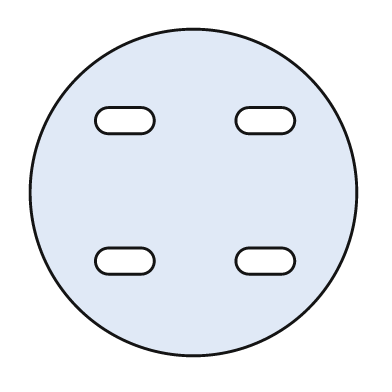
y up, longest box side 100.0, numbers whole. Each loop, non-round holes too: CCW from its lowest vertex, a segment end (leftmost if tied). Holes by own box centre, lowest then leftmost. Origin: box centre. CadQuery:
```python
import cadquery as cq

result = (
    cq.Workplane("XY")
    .moveTo(0.0, 0.0)
    .circle(50.0)
    .moveTo(-26.0, -25.0)
    .lineTo(-16.0, -25.0)
    .threePointArc((-12.0, -21.0), (-16.0, -17.0))
    .lineTo(-26.0, -17.0)
    .threePointArc((-30.0, -21.0), (-26.0, -25.0))
    .close()
    .moveTo(17.0, -25.0)
    .lineTo(27.0, -25.0)
    .threePointArc((31.0, -21.0), (27.0, -17.0))
    .lineTo(17.0, -17.0)
    .threePointArc((13.0, -21.0), (17.0, -25.0))
    .close()
    .moveTo(-26.0, 18.0)
    .lineTo(-16.0, 18.0)
    .threePointArc((-12.0, 22.0), (-16.0, 26.0))
    .lineTo(-26.0, 26.0)
    .threePointArc((-30.0, 22.0), (-26.0, 18.0))
    .close()
    .moveTo(17.0, 18.0)
    .lineTo(27.0, 18.0)
    .threePointArc((31.0, 22.0), (27.0, 26.0))
    .lineTo(17.0, 26.0)
    .threePointArc((13.0, 22.0), (17.0, 18.0))
    .close()
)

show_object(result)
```